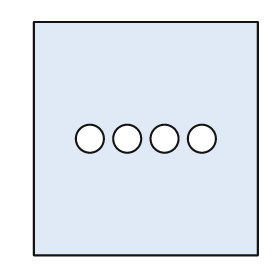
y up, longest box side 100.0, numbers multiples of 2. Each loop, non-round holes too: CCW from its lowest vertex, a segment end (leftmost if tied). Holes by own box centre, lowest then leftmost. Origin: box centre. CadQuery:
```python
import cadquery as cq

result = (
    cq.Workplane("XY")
    .moveTo(-48.0, -50.0)
    .lineTo(48.0, -50.0)
    .lineTo(48.0, 50.0)
    .lineTo(-48.0, 50.0)
    .close()
    .moveTo(-24.0, 0.0)
    .circle(6.0)
    .moveTo(-8.0, 0.0)
    .circle(6.0)
    .moveTo(8.0, 0.0)
    .circle(6.0)
    .moveTo(24.0, 0.0)
    .circle(6.0)
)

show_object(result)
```